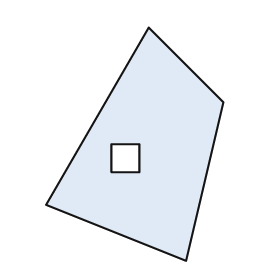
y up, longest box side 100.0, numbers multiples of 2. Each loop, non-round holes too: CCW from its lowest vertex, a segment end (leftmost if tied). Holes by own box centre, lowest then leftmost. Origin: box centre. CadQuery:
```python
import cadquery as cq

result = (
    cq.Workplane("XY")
    .moveTo(22.0, -50.0)
    .lineTo(38.0, 18.0)
    .lineTo(6.0, 50.0)
    .lineTo(-38.0, -26.0)
    .close()
    .moveTo(-10.0, -12.0)
    .lineTo(2.0, -12.0)
    .lineTo(2.0, 0.0)
    .lineTo(-10.0, 0.0)
    .close()
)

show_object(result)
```